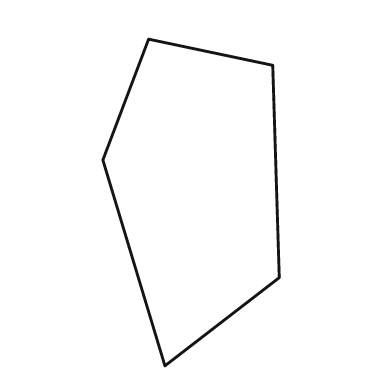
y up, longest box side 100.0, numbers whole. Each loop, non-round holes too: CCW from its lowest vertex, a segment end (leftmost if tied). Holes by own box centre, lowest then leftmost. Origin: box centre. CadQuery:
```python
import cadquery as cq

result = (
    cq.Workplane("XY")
    .moveTo(-8.0, -50.0)
    .lineTo(27.0, -23.0)
    .lineTo(25.0, 42.0)
    .lineTo(-13.0, 50.0)
    .lineTo(-27.0, 13.0)
    .close()
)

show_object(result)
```